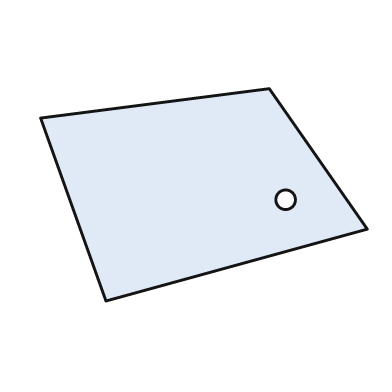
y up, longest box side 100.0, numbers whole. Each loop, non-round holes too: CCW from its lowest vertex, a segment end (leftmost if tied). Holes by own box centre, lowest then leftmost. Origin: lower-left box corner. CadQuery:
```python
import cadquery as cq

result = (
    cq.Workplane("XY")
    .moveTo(20.0, 0.0)
    .lineTo(100.0, 22.0)
    .lineTo(70.0, 65.0)
    .lineTo(0.0, 56.0)
    .close()
    .moveTo(75.0, 31.0)
    .circle(3.0)
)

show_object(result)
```